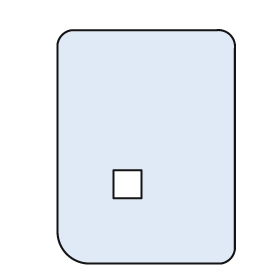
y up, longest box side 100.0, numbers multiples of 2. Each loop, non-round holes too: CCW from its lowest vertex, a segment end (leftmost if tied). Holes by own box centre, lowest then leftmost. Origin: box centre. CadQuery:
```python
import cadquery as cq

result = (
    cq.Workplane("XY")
    .moveTo(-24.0, -50.0)
    .lineTo(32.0, -50.0)
    .threePointArc((36.0, -48.0), (38.0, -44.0))
    .lineTo(38.0, 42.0)
    .threePointArc((36.0, 48.0), (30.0, 50.0))
    .lineTo(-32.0, 50.0)
    .threePointArc((-36.0, 48.0), (-38.0, 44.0))
    .lineTo(-38.0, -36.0)
    .threePointArc((-34.0, -46.0), (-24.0, -50.0))
    .close()
    .moveTo(-14.0, -22.0)
    .lineTo(-2.0, -22.0)
    .lineTo(-2.0, -10.0)
    .lineTo(-14.0, -10.0)
    .close()
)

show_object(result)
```